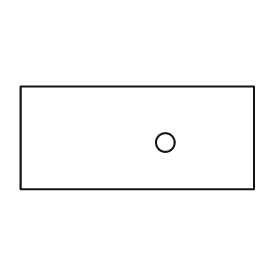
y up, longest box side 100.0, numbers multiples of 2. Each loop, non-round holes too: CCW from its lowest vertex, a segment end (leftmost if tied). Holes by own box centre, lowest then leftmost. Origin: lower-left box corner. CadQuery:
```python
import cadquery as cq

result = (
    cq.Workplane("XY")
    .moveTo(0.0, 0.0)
    .lineTo(100.0, 0.0)
    .lineTo(100.0, 44.0)
    .lineTo(0.0, 44.0)
    .close()
    .moveTo(62.0, 20.0)
    .circle(4.0)
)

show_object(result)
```